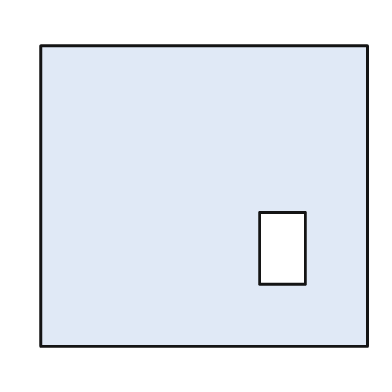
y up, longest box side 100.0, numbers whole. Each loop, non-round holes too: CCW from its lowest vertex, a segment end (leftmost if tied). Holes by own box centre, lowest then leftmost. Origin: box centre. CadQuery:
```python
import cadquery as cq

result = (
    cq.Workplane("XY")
    .moveTo(-50.0, -46.0)
    .lineTo(50.0, -46.0)
    .lineTo(50.0, 46.0)
    .lineTo(-50.0, 46.0)
    .close()
    .moveTo(17.0, -27.0)
    .lineTo(31.0, -27.0)
    .lineTo(31.0, -5.0)
    .lineTo(17.0, -5.0)
    .close()
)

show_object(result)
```